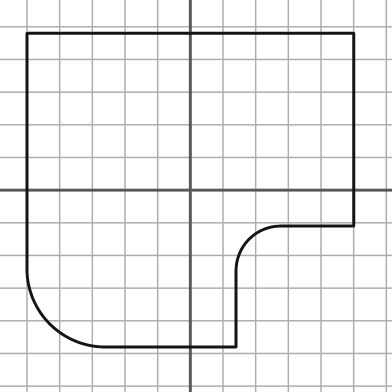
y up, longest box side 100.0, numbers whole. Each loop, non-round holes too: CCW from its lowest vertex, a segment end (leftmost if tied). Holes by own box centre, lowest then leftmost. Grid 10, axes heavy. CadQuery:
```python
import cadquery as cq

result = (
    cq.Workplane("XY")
    .moveTo(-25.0, -48.0)
    .lineTo(14.0, -48.0)
    .lineTo(14.0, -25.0)
    .threePointArc((18.0, -15.0), (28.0, -11.0))
    .lineTo(50.0, -11.0)
    .lineTo(50.0, 48.0)
    .lineTo(-50.0, 48.0)
    .lineTo(-50.0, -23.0)
    .threePointArc((-43.0, -41.0), (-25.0, -48.0))
    .close()
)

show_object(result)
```